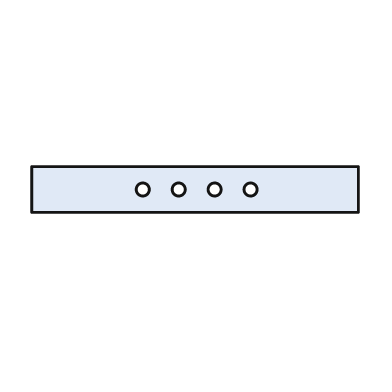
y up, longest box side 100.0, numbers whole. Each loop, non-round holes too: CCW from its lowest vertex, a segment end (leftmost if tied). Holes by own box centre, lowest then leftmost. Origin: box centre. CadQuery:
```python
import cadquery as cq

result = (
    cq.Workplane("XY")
    .moveTo(-50.0, -7.0)
    .lineTo(50.0, -7.0)
    .lineTo(50.0, 7.0)
    .lineTo(-50.0, 7.0)
    .close()
    .moveTo(-16.0, 0.0)
    .circle(2.0)
    .moveTo(-5.0, 0.0)
    .circle(2.0)
    .moveTo(6.0, 0.0)
    .circle(2.0)
    .moveTo(17.0, 0.0)
    .circle(2.0)
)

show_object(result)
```